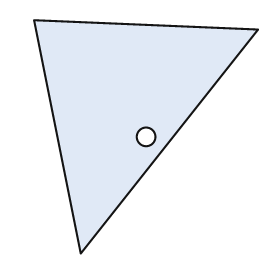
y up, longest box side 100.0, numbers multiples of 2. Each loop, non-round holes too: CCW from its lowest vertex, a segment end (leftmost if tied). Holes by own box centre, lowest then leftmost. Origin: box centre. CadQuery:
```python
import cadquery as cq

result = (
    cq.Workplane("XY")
    .moveTo(-28.0, -50.0)
    .lineTo(48.0, 46.0)
    .lineTo(-48.0, 50.0)
    .close()
    .moveTo(0.0, 0.0)
    .circle(4.0)
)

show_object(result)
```